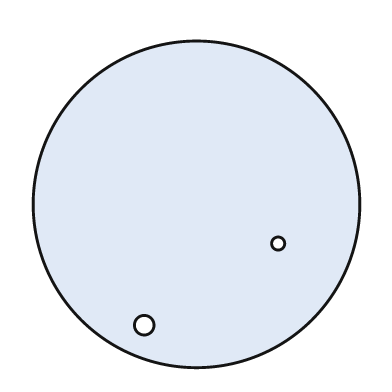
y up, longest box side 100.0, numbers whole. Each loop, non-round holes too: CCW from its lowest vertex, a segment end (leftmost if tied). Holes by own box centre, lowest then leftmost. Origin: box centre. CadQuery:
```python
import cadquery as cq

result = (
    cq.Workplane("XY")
    .moveTo(0.0, 0.0)
    .circle(50.0)
    .moveTo(-16.0, -37.0)
    .circle(3.0)
    .moveTo(25.0, -12.0)
    .circle(2.0)
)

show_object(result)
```